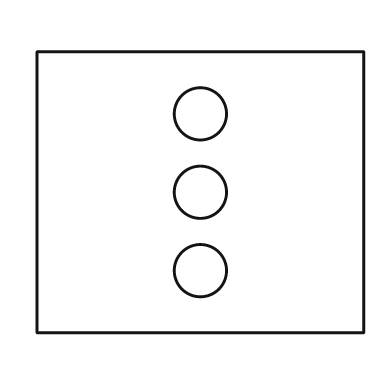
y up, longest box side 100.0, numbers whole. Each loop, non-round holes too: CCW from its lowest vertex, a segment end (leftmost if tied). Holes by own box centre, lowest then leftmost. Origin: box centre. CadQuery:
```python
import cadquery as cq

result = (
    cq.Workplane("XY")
    .moveTo(-50.0, -43.0)
    .lineTo(50.0, -43.0)
    .lineTo(50.0, 43.0)
    .lineTo(-50.0, 43.0)
    .close()
    .moveTo(0.0, -24.0)
    .circle(8.0)
    .moveTo(0.0, 0.0)
    .circle(8.0)
    .moveTo(0.0, 24.0)
    .circle(8.0)
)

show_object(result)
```